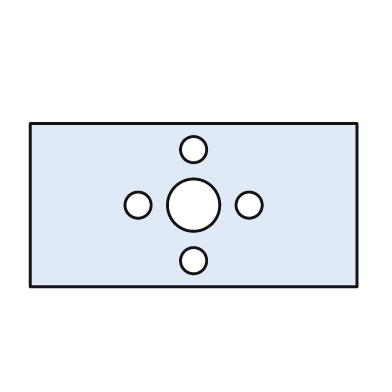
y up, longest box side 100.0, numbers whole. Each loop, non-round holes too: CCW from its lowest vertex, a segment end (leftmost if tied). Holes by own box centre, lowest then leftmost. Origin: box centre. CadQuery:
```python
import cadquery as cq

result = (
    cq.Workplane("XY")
    .moveTo(-50.0, -25.0)
    .lineTo(50.0, -25.0)
    .lineTo(50.0, 25.0)
    .lineTo(-50.0, 25.0)
    .close()
    .moveTo(0.0, -17.0)
    .circle(4.0)
    .moveTo(-17.0, 0.0)
    .circle(4.0)
    .moveTo(0.0, 0.0)
    .circle(8.0)
    .moveTo(17.0, 0.0)
    .circle(4.0)
    .moveTo(0.0, 17.0)
    .circle(4.0)
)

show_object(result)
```